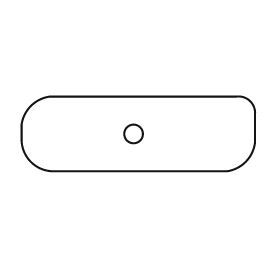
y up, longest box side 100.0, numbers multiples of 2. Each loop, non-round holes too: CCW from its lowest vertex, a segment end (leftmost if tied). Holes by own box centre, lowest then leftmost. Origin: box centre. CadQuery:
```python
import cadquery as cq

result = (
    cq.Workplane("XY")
    .moveTo(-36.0, -16.0)
    .lineTo(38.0, -16.0)
    .threePointArc((46.0, -12.0), (50.0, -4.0))
    .lineTo(50.0, 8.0)
    .threePointArc((48.0, 14.0), (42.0, 16.0))
    .lineTo(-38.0, 16.0)
    .threePointArc((-46.0, 12.0), (-50.0, 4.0))
    .lineTo(-50.0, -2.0)
    .threePointArc((-46.0, -12.0), (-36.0, -16.0))
    .close()
    .moveTo(-2.0, 0.0)
    .circle(4.0)
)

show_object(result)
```